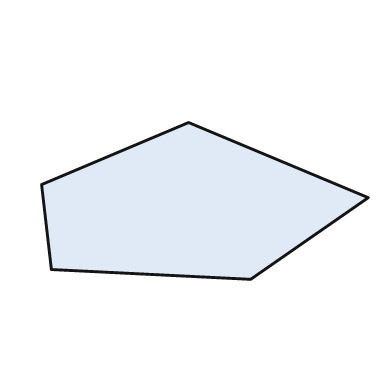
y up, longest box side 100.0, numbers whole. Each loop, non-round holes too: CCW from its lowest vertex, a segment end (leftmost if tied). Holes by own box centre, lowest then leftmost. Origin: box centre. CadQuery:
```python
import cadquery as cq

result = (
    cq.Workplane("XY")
    .moveTo(14.0, -24.0)
    .lineTo(50.0, 1.0)
    .lineTo(-5.0, 24.0)
    .lineTo(-50.0, 5.0)
    .lineTo(-47.0, -21.0)
    .close()
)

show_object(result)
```